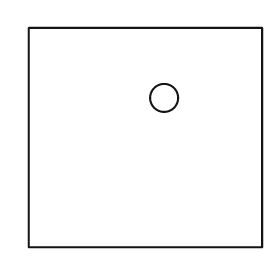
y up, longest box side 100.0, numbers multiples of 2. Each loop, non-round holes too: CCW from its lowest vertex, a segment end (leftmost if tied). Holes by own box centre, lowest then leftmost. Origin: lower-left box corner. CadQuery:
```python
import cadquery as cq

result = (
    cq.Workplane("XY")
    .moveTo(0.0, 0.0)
    .lineTo(100.0, 0.0)
    .lineTo(100.0, 94.0)
    .lineTo(0.0, 94.0)
    .close()
    .moveTo(58.0, 64.0)
    .circle(6.0)
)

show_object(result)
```